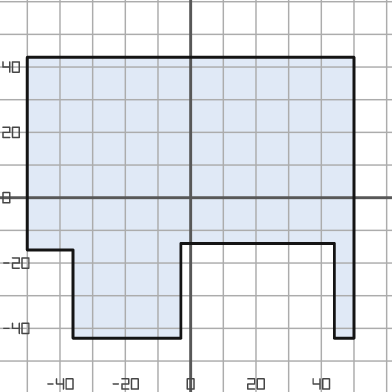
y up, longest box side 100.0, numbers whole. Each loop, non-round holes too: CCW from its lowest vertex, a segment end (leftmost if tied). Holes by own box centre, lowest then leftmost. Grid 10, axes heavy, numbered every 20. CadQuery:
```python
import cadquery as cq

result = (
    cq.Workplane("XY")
    .moveTo(-36.0, -43.0)
    .lineTo(-3.0, -43.0)
    .lineTo(-3.0, -14.0)
    .lineTo(44.0, -14.0)
    .lineTo(44.0, -43.0)
    .lineTo(50.0, -43.0)
    .lineTo(50.0, 43.0)
    .lineTo(-50.0, 43.0)
    .lineTo(-50.0, -16.0)
    .lineTo(-36.0, -16.0)
    .close()
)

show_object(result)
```